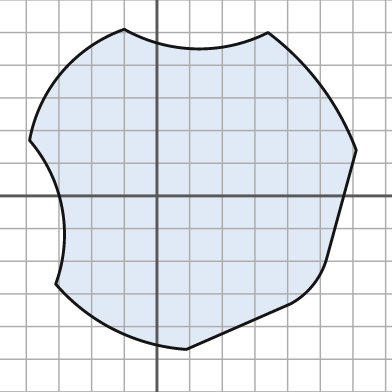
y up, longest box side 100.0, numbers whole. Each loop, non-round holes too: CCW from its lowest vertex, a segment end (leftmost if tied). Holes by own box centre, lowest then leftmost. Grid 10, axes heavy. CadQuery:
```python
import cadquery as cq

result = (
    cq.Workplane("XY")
    .moveTo(9.0, -47.0)
    .lineTo(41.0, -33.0)
    .threePointArc((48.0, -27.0), (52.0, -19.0))
    .lineTo(61.0, 14.0)
    .threePointArc((50.0, 34.0), (34.0, 50.0))
    .threePointArc((12.0, 45.0), (-10.0, 51.0))
    .threePointArc((-29.0, 38.0), (-39.0, 17.0))
    .threePointArc((-29.0, -4.0), (-31.0, -27.0))
    .threePointArc((-13.0, -41.0), (9.0, -47.0))
    .close()
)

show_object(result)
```